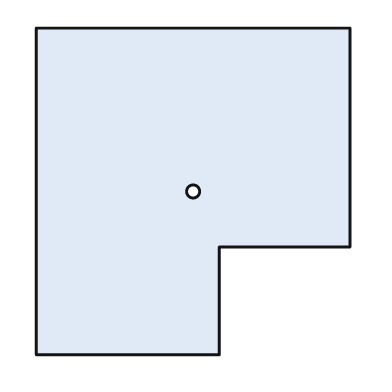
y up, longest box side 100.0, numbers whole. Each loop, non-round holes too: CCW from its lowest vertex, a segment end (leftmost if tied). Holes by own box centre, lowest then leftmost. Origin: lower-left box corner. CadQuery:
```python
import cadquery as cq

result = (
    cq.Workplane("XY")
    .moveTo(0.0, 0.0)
    .lineTo(56.0, 0.0)
    .lineTo(56.0, 33.0)
    .lineTo(96.0, 33.0)
    .lineTo(96.0, 100.0)
    .lineTo(0.0, 100.0)
    .close()
    .moveTo(48.0, 50.0)
    .circle(2.0)
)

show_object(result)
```